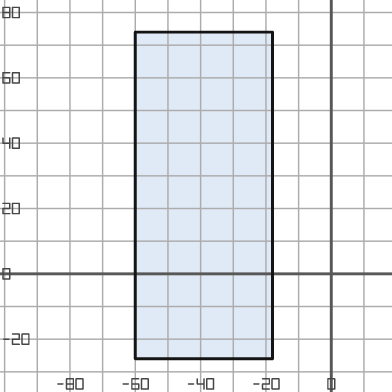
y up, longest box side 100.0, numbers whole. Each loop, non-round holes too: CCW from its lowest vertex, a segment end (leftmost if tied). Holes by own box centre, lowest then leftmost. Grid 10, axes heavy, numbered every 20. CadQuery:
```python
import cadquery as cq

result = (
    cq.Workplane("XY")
    .moveTo(-60.0, -26.0)
    .lineTo(-18.0, -26.0)
    .lineTo(-18.0, 74.0)
    .lineTo(-60.0, 74.0)
    .close()
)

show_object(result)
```